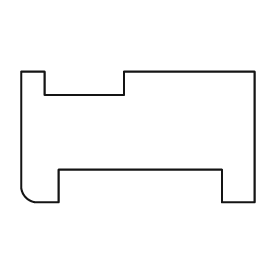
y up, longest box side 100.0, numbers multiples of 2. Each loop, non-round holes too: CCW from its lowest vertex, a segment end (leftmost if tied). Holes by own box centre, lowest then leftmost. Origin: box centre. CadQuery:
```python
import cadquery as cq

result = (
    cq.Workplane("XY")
    .moveTo(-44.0, -28.0)
    .lineTo(-34.0, -28.0)
    .lineTo(-34.0, -14.0)
    .lineTo(36.0, -14.0)
    .lineTo(36.0, -28.0)
    .lineTo(50.0, -28.0)
    .lineTo(50.0, 28.0)
    .lineTo(-6.0, 28.0)
    .lineTo(-6.0, 18.0)
    .lineTo(-40.0, 18.0)
    .lineTo(-40.0, 28.0)
    .lineTo(-50.0, 28.0)
    .lineTo(-50.0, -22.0)
    .threePointArc((-48.0, -26.0), (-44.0, -28.0))
    .close()
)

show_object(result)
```